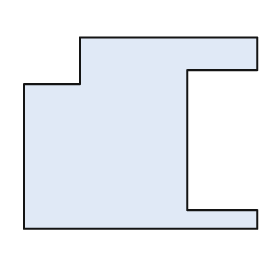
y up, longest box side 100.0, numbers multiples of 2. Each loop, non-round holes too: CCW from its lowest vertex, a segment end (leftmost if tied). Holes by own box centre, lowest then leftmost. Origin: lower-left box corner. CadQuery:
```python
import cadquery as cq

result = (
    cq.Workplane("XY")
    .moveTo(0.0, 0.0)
    .lineTo(100.0, 0.0)
    .lineTo(100.0, 8.0)
    .lineTo(70.0, 8.0)
    .lineTo(70.0, 68.0)
    .lineTo(100.0, 68.0)
    .lineTo(100.0, 82.0)
    .lineTo(24.0, 82.0)
    .lineTo(24.0, 62.0)
    .lineTo(0.0, 62.0)
    .close()
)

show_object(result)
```